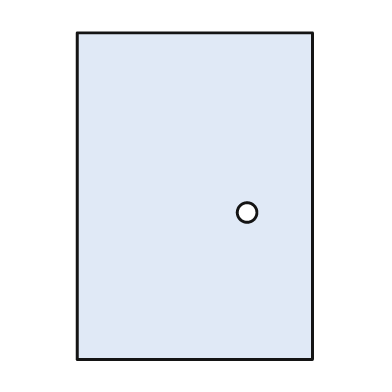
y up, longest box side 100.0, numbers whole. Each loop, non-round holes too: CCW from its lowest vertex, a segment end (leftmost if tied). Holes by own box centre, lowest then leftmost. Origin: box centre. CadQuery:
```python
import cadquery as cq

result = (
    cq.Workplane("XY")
    .moveTo(-36.0, -50.0)
    .lineTo(36.0, -50.0)
    .lineTo(36.0, 50.0)
    .lineTo(-36.0, 50.0)
    .close()
    .moveTo(16.0, -5.0)
    .circle(3.0)
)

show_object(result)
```